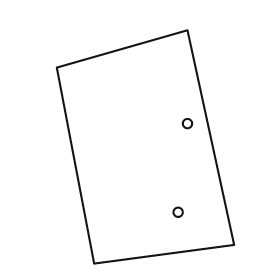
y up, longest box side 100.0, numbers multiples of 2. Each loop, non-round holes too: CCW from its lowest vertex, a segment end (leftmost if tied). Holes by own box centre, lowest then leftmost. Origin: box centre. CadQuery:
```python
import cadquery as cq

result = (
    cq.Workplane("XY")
    .moveTo(-22.0, -50.0)
    .lineTo(38.0, -42.0)
    .lineTo(18.0, 50.0)
    .lineTo(-38.0, 34.0)
    .close()
    .moveTo(14.0, -28.0)
    .circle(2.0)
    .moveTo(18.0, 10.0)
    .circle(2.0)
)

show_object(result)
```